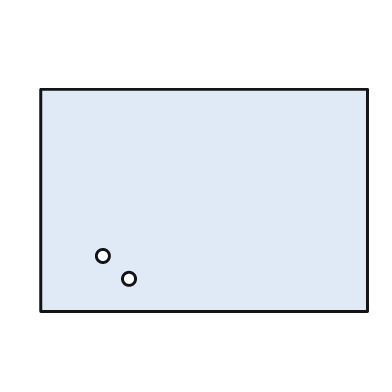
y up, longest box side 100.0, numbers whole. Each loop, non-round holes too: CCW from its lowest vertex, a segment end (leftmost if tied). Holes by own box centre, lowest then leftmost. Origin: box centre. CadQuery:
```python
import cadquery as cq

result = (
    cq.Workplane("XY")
    .moveTo(-50.0, -34.0)
    .lineTo(50.0, -34.0)
    .lineTo(50.0, 34.0)
    .lineTo(-50.0, 34.0)
    .close()
    .moveTo(-23.0, -24.0)
    .circle(2.0)
    .moveTo(-31.0, -17.0)
    .circle(2.0)
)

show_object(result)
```